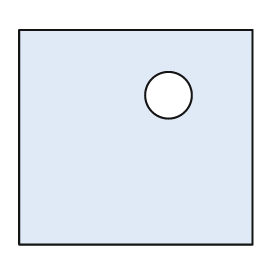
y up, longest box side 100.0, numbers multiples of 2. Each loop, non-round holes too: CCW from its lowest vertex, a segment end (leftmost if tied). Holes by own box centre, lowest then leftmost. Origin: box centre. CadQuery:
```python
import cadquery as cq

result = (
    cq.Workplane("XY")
    .moveTo(-50.0, -46.0)
    .lineTo(50.0, -46.0)
    .lineTo(50.0, 46.0)
    .lineTo(-50.0, 46.0)
    .close()
    .moveTo(14.0, 18.0)
    .circle(10.0)
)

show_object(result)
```